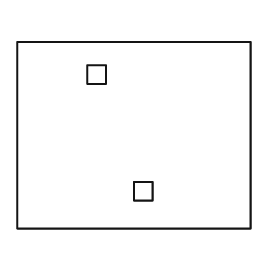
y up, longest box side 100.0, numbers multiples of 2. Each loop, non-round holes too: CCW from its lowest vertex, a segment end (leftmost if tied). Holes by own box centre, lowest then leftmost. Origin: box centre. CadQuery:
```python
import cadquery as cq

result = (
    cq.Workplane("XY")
    .moveTo(-50.0, -40.0)
    .lineTo(50.0, -40.0)
    .lineTo(50.0, 40.0)
    .lineTo(-50.0, 40.0)
    .close()
    .moveTo(0.0, -28.0)
    .lineTo(8.0, -28.0)
    .lineTo(8.0, -20.0)
    .lineTo(0.0, -20.0)
    .close()
    .moveTo(-20.0, 22.0)
    .lineTo(-12.0, 22.0)
    .lineTo(-12.0, 30.0)
    .lineTo(-20.0, 30.0)
    .close()
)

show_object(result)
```